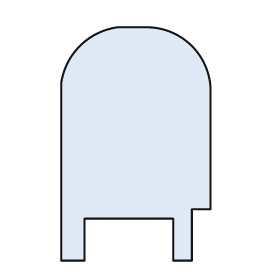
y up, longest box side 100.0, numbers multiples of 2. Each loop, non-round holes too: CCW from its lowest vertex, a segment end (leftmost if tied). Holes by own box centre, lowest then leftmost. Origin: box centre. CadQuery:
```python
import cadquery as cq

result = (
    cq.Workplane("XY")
    .moveTo(-32.0, -50.0)
    .lineTo(-22.0, -50.0)
    .lineTo(-22.0, -32.0)
    .lineTo(16.0, -32.0)
    .lineTo(16.0, -50.0)
    .lineTo(24.0, -50.0)
    .lineTo(24.0, -28.0)
    .lineTo(32.0, -28.0)
    .lineTo(32.0, 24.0)
    .threePointArc((24.0, 42.0), (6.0, 50.0))
    .lineTo(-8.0, 50.0)
    .threePointArc((-24.0, 42.0), (-32.0, 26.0))
    .close()
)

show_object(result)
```